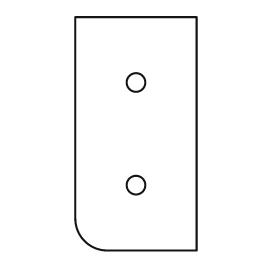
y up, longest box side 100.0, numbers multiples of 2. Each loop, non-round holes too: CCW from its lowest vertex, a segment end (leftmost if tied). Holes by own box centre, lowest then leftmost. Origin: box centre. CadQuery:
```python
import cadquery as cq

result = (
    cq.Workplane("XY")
    .moveTo(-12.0, -50.0)
    .lineTo(26.0, -50.0)
    .lineTo(26.0, 50.0)
    .lineTo(-26.0, 50.0)
    .lineTo(-26.0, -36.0)
    .threePointArc((-22.0, -46.0), (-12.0, -50.0))
    .close()
    .moveTo(0.0, -22.0)
    .circle(4.0)
    .moveTo(0.0, 22.0)
    .circle(4.0)
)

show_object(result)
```